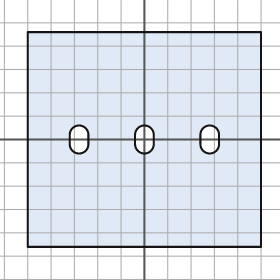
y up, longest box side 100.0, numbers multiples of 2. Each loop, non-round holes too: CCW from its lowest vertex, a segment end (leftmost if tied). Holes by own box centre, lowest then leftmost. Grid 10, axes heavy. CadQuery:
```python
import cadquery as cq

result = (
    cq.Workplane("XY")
    .moveTo(-50.0, -46.0)
    .lineTo(50.0, -46.0)
    .lineTo(50.0, 46.0)
    .lineTo(-50.0, 46.0)
    .close()
    .moveTo(-32.0, -2.0)
    .threePointArc((-28.0, -6.0), (-24.0, -2.0))
    .lineTo(-24.0, 2.0)
    .threePointArc((-28.0, 6.0), (-32.0, 2.0))
    .close()
    .moveTo(-4.0, -2.0)
    .threePointArc((0.0, -6.0), (4.0, -2.0))
    .lineTo(4.0, 2.0)
    .threePointArc((0.0, 6.0), (-4.0, 2.0))
    .close()
    .moveTo(24.0, -2.0)
    .threePointArc((28.0, -6.0), (32.0, -2.0))
    .lineTo(32.0, 2.0)
    .threePointArc((28.0, 6.0), (24.0, 2.0))
    .close()
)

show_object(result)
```